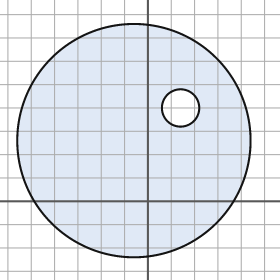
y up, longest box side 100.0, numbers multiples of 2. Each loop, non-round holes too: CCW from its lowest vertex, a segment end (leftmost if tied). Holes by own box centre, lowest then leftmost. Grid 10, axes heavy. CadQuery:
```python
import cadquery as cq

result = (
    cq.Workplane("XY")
    .moveTo(-6.0, 26.0)
    .circle(50.0)
    .moveTo(14.0, 40.0)
    .circle(8.0)
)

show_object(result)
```